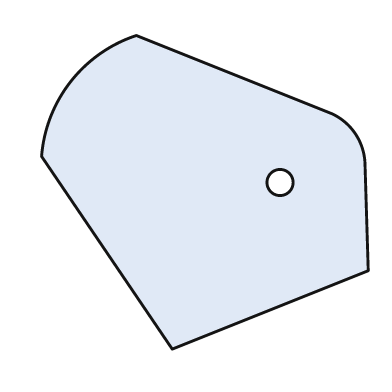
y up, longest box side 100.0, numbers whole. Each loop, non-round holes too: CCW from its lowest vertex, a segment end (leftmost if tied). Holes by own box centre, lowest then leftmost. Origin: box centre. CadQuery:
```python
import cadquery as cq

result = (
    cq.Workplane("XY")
    .moveTo(-10.0, -48.0)
    .lineTo(50.0, -24.0)
    .lineTo(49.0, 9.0)
    .threePointArc((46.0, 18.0), (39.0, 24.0))
    .lineTo(-21.0, 48.0)
    .threePointArc((-41.0, 34.0), (-50.0, 11.0))
    .close()
    .moveTo(23.0, 3.0)
    .circle(4.0)
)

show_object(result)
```